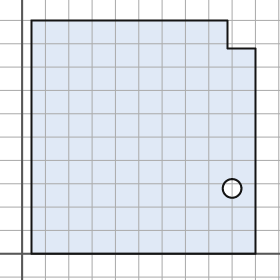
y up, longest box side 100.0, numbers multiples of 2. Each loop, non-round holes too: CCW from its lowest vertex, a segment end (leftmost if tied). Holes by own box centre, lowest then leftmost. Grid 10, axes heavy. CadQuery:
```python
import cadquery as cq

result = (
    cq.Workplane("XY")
    .moveTo(4.0, 0.0)
    .lineTo(100.0, 0.0)
    .lineTo(100.0, 88.0)
    .lineTo(88.0, 88.0)
    .lineTo(88.0, 100.0)
    .lineTo(4.0, 100.0)
    .close()
    .moveTo(90.0, 28.0)
    .circle(4.0)
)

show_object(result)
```